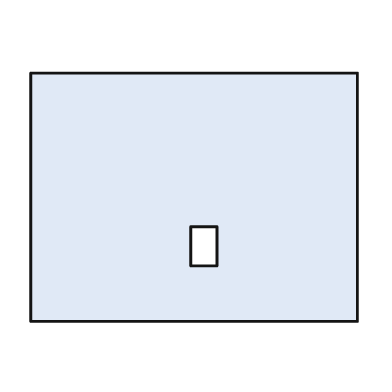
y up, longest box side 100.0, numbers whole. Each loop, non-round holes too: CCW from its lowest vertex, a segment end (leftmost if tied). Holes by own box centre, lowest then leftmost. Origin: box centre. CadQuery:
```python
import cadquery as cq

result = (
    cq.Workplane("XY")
    .moveTo(-50.0, -38.0)
    .lineTo(50.0, -38.0)
    .lineTo(50.0, 38.0)
    .lineTo(-50.0, 38.0)
    .close()
    .moveTo(-1.0, -21.0)
    .lineTo(7.0, -21.0)
    .lineTo(7.0, -9.0)
    .lineTo(-1.0, -9.0)
    .close()
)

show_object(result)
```